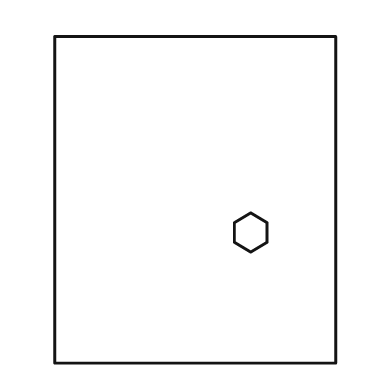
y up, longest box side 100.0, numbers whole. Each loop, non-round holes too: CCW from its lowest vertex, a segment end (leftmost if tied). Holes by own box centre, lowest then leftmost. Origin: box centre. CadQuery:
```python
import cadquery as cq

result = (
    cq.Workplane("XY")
    .moveTo(-43.0, -50.0)
    .lineTo(43.0, -50.0)
    .lineTo(43.0, 50.0)
    .lineTo(-43.0, 50.0)
    .close()
    .moveTo(17.0, -16.0)
    .lineTo(22.0, -13.0)
    .lineTo(22.0, -7.0)
    .lineTo(17.0, -4.0)
    .lineTo(12.0, -7.0)
    .lineTo(12.0, -13.0)
    .close()
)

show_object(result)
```